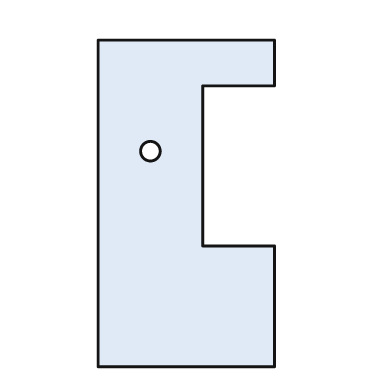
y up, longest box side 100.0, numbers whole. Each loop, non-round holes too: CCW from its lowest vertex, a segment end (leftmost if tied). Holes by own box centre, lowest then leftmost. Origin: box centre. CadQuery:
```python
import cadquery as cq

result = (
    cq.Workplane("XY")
    .moveTo(-27.0, -50.0)
    .lineTo(27.0, -50.0)
    .lineTo(27.0, -13.0)
    .lineTo(5.0, -13.0)
    .lineTo(5.0, 36.0)
    .lineTo(27.0, 36.0)
    .lineTo(27.0, 50.0)
    .lineTo(-27.0, 50.0)
    .close()
    .moveTo(-11.0, 16.0)
    .circle(3.0)
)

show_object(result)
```